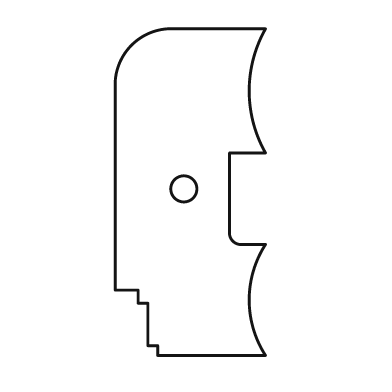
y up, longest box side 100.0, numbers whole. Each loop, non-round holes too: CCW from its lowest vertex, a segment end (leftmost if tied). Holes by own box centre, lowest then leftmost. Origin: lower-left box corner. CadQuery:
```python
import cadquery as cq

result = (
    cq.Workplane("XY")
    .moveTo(13.0, 0.0)
    .lineTo(46.0, 0.0)
    .threePointArc((41.0, 17.0), (46.0, 34.0))
    .lineTo(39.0, 34.0)
    .threePointArc((36.0, 35.0), (35.0, 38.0))
    .lineTo(35.0, 62.0)
    .lineTo(46.0, 62.0)
    .threePointArc((41.0, 81.0), (46.0, 100.0))
    .lineTo(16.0, 100.0)
    .threePointArc((5.0, 95.0), (0.0, 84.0))
    .lineTo(0.0, 20.0)
    .lineTo(7.0, 20.0)
    .lineTo(7.0, 16.0)
    .lineTo(10.0, 16.0)
    .lineTo(10.0, 3.0)
    .lineTo(13.0, 3.0)
    .close()
    .moveTo(21.0, 51.0)
    .circle(4.0)
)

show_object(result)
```